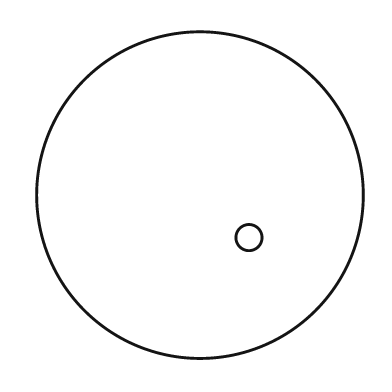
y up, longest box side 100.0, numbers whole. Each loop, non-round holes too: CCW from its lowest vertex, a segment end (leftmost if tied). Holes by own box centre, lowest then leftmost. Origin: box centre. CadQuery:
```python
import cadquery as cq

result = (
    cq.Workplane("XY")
    .moveTo(0.0, 0.0)
    .circle(50.0)
    .moveTo(15.0, -13.0)
    .circle(4.0)
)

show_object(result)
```